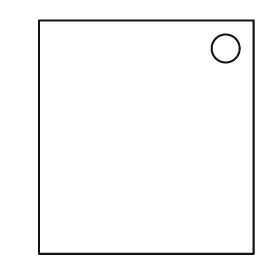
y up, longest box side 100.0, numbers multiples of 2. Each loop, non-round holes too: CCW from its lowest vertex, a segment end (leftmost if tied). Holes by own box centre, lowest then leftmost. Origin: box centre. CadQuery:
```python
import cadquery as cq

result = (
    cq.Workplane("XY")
    .moveTo(-46.0, -50.0)
    .lineTo(46.0, -50.0)
    .lineTo(46.0, 50.0)
    .lineTo(-46.0, 50.0)
    .close()
    .moveTo(34.0, 38.0)
    .circle(6.0)
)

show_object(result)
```